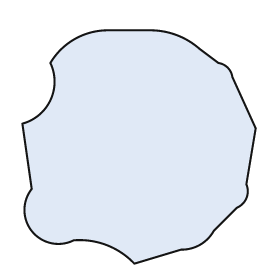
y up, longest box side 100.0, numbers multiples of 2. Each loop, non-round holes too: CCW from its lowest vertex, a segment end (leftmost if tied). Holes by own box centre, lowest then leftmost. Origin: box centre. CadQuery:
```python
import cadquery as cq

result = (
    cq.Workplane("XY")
    .moveTo(-2.0, -50.0)
    .lineTo(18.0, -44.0)
    .threePointArc((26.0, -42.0), (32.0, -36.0))
    .lineTo(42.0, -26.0)
    .threePointArc((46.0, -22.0), (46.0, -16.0))
    .lineTo(50.0, 8.0)
    .lineTo(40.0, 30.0)
    .threePointArc((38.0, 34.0), (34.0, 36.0))
    .lineTo(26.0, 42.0)
    .threePointArc((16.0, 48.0), (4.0, 50.0))
    .lineTo(-14.0, 50.0)
    .threePointArc((-28.0, 46.0), (-38.0, 36.0))
    .threePointArc((-38.0, 20.0), (-50.0, 10.0))
    .lineTo(-46.0, -18.0)
    .threePointArc((-46.0, -36.0), (-28.0, -40.0))
    .threePointArc((-14.0, -42.0), (-2.0, -50.0))
    .close()
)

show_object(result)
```